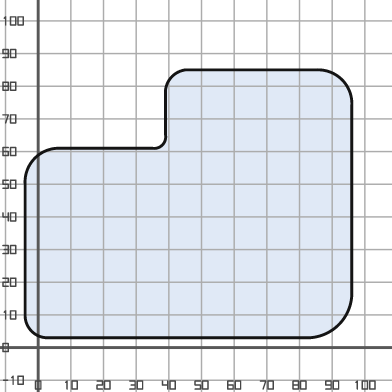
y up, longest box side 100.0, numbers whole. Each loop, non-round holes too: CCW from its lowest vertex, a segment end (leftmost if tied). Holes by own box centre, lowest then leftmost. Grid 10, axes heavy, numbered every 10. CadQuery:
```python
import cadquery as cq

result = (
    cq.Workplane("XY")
    .moveTo(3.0, 3.0)
    .lineTo(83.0, 3.0)
    .threePointArc((92.0, 7.0), (96.0, 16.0))
    .lineTo(96.0, 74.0)
    .threePointArc((93.0, 82.0), (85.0, 85.0))
    .lineTo(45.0, 85.0)
    .threePointArc((41.0, 83.0), (39.0, 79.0))
    .lineTo(39.0, 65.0)
    .threePointArc((38.0, 62.0), (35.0, 61.0))
    .lineTo(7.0, 61.0)
    .threePointArc((-1.0, 58.0), (-4.0, 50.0))
    .lineTo(-4.0, 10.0)
    .threePointArc((-2.0, 5.0), (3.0, 3.0))
    .close()
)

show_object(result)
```